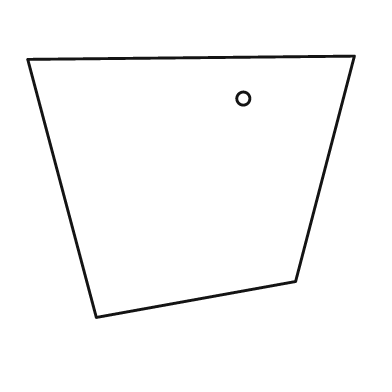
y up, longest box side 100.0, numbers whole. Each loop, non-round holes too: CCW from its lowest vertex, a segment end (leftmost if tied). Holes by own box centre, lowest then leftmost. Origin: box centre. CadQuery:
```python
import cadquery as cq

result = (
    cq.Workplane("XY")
    .moveTo(-29.0, -40.0)
    .lineTo(32.0, -29.0)
    .lineTo(50.0, 40.0)
    .lineTo(-50.0, 39.0)
    .close()
    .moveTo(16.0, 27.0)
    .circle(2.0)
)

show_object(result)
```